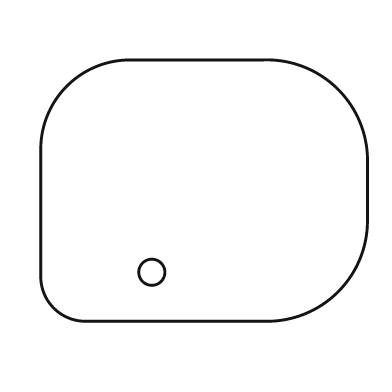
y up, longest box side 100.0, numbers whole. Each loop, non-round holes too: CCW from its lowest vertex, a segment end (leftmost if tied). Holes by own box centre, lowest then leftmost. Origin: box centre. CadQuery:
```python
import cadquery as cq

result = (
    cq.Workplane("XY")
    .moveTo(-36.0, -40.0)
    .lineTo(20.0, -40.0)
    .threePointArc((41.0, -31.0), (50.0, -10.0))
    .lineTo(50.0, 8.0)
    .threePointArc((41.0, 31.0), (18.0, 40.0))
    .lineTo(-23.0, 40.0)
    .threePointArc((-42.0, 32.0), (-50.0, 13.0))
    .lineTo(-50.0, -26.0)
    .threePointArc((-46.0, -36.0), (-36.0, -40.0))
    .close()
    .moveTo(-16.0, -25.0)
    .circle(4.0)
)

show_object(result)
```